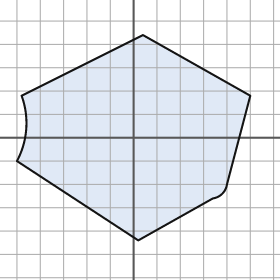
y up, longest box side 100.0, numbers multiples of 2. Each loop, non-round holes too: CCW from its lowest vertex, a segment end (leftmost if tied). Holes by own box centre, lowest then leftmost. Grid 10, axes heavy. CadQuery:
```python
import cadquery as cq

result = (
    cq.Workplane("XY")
    .moveTo(2.0, -44.0)
    .lineTo(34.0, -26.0)
    .threePointArc((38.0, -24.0), (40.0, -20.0))
    .lineTo(50.0, 18.0)
    .lineTo(4.0, 44.0)
    .lineTo(-48.0, 18.0)
    .threePointArc((-46.0, 4.0), (-50.0, -10.0))
    .close()
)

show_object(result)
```